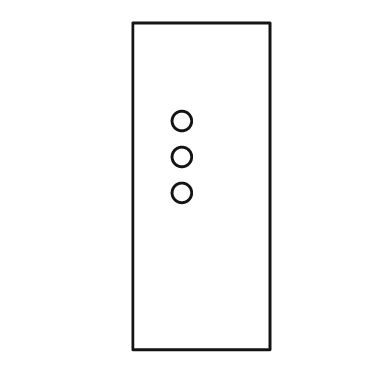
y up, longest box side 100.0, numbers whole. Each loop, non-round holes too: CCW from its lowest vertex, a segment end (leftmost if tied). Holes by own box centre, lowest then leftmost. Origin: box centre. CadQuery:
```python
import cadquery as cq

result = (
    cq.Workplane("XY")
    .moveTo(-21.0, -50.0)
    .lineTo(21.0, -50.0)
    .lineTo(21.0, 50.0)
    .lineTo(-21.0, 50.0)
    .close()
    .moveTo(-6.0, -2.0)
    .circle(3.0)
    .moveTo(-6.0, 9.0)
    .circle(3.0)
    .moveTo(-6.0, 20.0)
    .circle(3.0)
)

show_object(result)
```